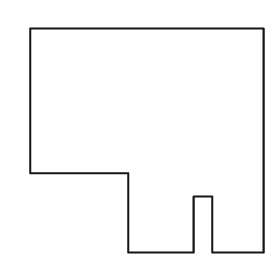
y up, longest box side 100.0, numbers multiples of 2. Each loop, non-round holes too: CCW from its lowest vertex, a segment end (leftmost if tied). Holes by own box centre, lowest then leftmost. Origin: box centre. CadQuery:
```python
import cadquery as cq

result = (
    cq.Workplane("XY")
    .moveTo(-8.0, -48.0)
    .lineTo(20.0, -48.0)
    .lineTo(20.0, -24.0)
    .lineTo(28.0, -24.0)
    .lineTo(28.0, -48.0)
    .lineTo(50.0, -48.0)
    .lineTo(50.0, 48.0)
    .lineTo(-50.0, 48.0)
    .lineTo(-50.0, -14.0)
    .lineTo(-8.0, -14.0)
    .close()
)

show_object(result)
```